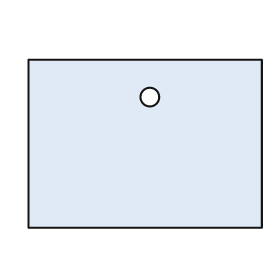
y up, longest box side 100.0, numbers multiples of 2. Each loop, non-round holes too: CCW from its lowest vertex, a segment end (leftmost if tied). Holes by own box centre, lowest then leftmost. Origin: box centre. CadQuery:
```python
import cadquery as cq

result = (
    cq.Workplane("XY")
    .moveTo(-50.0, -36.0)
    .lineTo(50.0, -36.0)
    .lineTo(50.0, 36.0)
    .lineTo(-50.0, 36.0)
    .close()
    .moveTo(2.0, 20.0)
    .circle(4.0)
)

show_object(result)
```